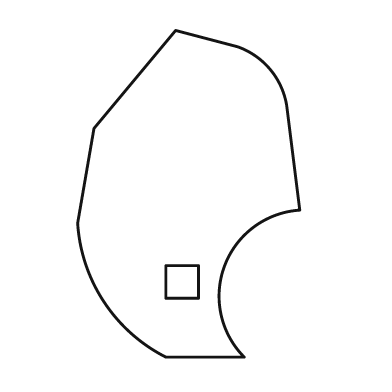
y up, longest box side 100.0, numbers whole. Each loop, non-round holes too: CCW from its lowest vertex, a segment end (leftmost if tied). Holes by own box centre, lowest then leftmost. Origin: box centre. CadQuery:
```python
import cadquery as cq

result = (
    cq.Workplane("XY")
    .moveTo(-7.0, -50.0)
    .lineTo(17.0, -50.0)
    .threePointArc((11.0, -22.0), (34.0, -5.0))
    .lineTo(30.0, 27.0)
    .threePointArc((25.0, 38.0), (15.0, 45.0))
    .lineTo(-4.0, 50.0)
    .lineTo(-29.0, 20.0)
    .lineTo(-34.0, -9.0)
    .threePointArc((-26.0, -33.0), (-7.0, -50.0))
    .close()
    .moveTo(-7.0, -32.0)
    .lineTo(3.0, -32.0)
    .lineTo(3.0, -22.0)
    .lineTo(-7.0, -22.0)
    .close()
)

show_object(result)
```